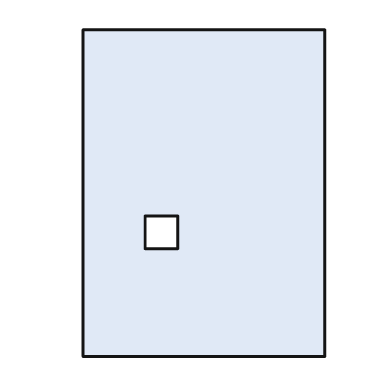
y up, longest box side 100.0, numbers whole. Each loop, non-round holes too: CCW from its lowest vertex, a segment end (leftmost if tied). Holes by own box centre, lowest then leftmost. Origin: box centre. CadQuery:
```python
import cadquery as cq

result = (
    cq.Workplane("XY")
    .moveTo(-37.0, -50.0)
    .lineTo(37.0, -50.0)
    .lineTo(37.0, 50.0)
    .lineTo(-37.0, 50.0)
    .close()
    .moveTo(-18.0, -17.0)
    .lineTo(-8.0, -17.0)
    .lineTo(-8.0, -7.0)
    .lineTo(-18.0, -7.0)
    .close()
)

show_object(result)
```